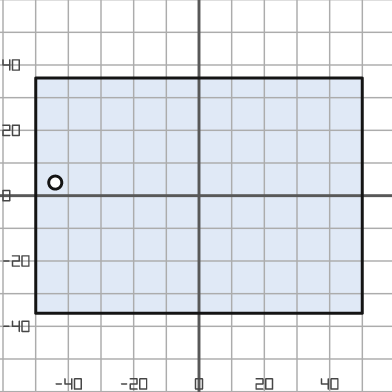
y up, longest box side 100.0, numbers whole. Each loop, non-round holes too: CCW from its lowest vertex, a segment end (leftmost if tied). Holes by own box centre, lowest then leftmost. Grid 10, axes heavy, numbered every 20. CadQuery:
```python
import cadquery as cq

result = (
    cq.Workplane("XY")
    .moveTo(-50.0, -36.0)
    .lineTo(50.0, -36.0)
    .lineTo(50.0, 36.0)
    .lineTo(-50.0, 36.0)
    .close()
    .moveTo(-44.0, 4.0)
    .circle(2.0)
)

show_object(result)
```